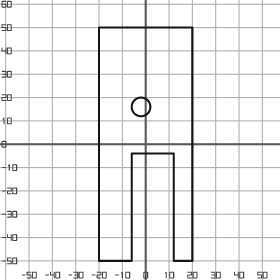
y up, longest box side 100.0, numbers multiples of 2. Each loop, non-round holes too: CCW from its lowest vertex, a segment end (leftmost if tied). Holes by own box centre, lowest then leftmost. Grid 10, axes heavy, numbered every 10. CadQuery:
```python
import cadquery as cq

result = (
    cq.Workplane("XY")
    .moveTo(-20.0, -50.0)
    .lineTo(-6.0, -50.0)
    .lineTo(-6.0, -4.0)
    .lineTo(12.0, -4.0)
    .lineTo(12.0, -50.0)
    .lineTo(20.0, -50.0)
    .lineTo(20.0, 50.0)
    .lineTo(-20.0, 50.0)
    .close()
    .moveTo(-2.0, 16.0)
    .circle(4.0)
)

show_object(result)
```